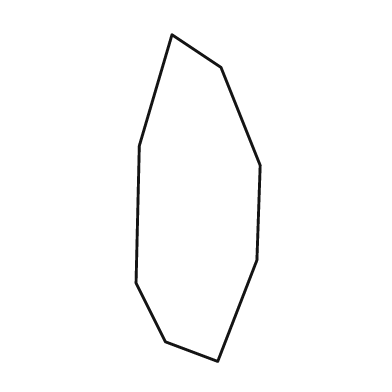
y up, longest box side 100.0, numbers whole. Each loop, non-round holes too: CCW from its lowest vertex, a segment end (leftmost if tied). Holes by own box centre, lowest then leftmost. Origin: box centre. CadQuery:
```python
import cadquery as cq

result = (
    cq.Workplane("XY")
    .moveTo(6.0, -50.0)
    .lineTo(18.0, -19.0)
    .lineTo(19.0, 10.0)
    .lineTo(7.0, 40.0)
    .lineTo(-8.0, 50.0)
    .lineTo(-18.0, 16.0)
    .lineTo(-19.0, -26.0)
    .lineTo(-10.0, -44.0)
    .close()
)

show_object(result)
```